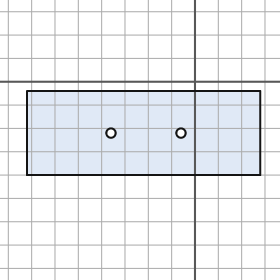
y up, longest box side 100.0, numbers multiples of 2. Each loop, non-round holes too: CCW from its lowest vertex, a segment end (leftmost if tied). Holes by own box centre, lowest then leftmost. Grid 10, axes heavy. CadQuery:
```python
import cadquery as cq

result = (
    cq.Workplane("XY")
    .moveTo(-72.0, -40.0)
    .lineTo(28.0, -40.0)
    .lineTo(28.0, -4.0)
    .lineTo(-72.0, -4.0)
    .close()
    .moveTo(-36.0, -22.0)
    .circle(2.0)
    .moveTo(-6.0, -22.0)
    .circle(2.0)
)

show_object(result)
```